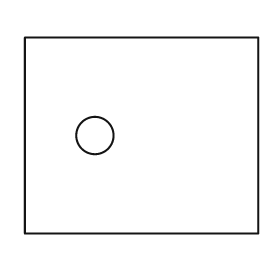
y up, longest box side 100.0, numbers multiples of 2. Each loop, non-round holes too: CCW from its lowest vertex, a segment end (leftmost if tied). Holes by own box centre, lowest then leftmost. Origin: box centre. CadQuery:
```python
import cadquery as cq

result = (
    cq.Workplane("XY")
    .moveTo(-50.0, -42.0)
    .lineTo(50.0, -42.0)
    .lineTo(50.0, 42.0)
    .lineTo(-50.0, 42.0)
    .close()
    .moveTo(-20.0, 0.0)
    .circle(8.0)
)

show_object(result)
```